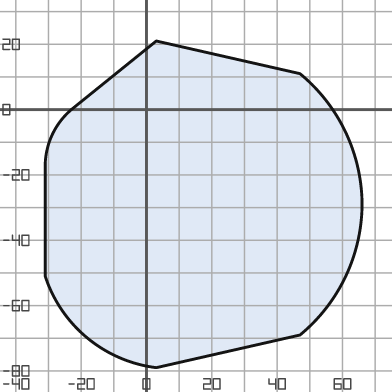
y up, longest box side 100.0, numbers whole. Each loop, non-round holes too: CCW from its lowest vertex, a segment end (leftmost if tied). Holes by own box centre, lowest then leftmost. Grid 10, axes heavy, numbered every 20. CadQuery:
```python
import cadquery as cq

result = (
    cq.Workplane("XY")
    .moveTo(3.0, -79.0)
    .lineTo(47.0, -69.0)
    .threePointArc((61.0, -51.0), (66.0, -29.0))
    .threePointArc((61.0, -7.0), (47.0, 11.0))
    .lineTo(3.0, 21.0)
    .lineTo(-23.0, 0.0)
    .threePointArc((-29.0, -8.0), (-31.0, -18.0))
    .lineTo(-31.0, -51.0)
    .threePointArc((-18.0, -70.0), (3.0, -79.0))
    .close()
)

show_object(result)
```